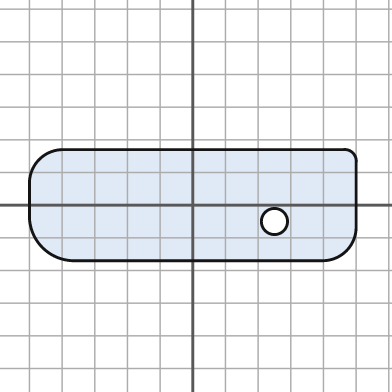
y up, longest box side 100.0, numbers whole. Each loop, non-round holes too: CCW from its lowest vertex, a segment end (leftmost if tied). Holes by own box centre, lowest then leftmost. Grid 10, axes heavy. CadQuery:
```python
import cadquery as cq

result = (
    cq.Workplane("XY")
    .moveTo(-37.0, -17.0)
    .lineTo(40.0, -17.0)
    .threePointArc((47.0, -14.0), (50.0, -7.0))
    .lineTo(50.0, 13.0)
    .threePointArc((49.0, 16.0), (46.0, 17.0))
    .lineTo(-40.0, 17.0)
    .threePointArc((-47.0, 14.0), (-50.0, 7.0))
    .lineTo(-50.0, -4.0)
    .threePointArc((-46.0, -13.0), (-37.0, -17.0))
    .close()
    .moveTo(25.0, -5.0)
    .circle(4.0)
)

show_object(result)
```